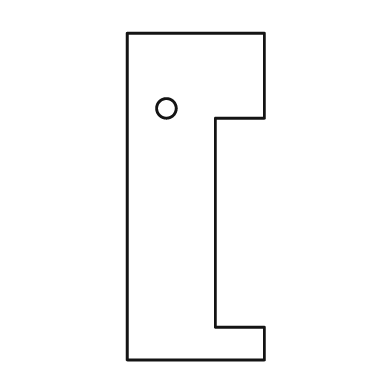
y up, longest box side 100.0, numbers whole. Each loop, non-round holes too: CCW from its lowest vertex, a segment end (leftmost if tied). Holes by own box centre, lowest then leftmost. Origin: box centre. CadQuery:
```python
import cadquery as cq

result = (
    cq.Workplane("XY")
    .moveTo(-21.0, -50.0)
    .lineTo(21.0, -50.0)
    .lineTo(21.0, -40.0)
    .lineTo(6.0, -40.0)
    .lineTo(6.0, 24.0)
    .lineTo(21.0, 24.0)
    .lineTo(21.0, 50.0)
    .lineTo(-21.0, 50.0)
    .close()
    .moveTo(-9.0, 27.0)
    .circle(3.0)
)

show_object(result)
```